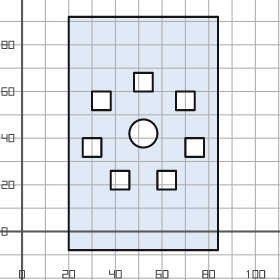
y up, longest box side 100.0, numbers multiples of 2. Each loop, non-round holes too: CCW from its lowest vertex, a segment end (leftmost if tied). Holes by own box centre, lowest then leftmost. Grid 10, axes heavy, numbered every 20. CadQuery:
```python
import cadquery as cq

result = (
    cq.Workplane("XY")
    .moveTo(20.0, -8.0)
    .lineTo(84.0, -8.0)
    .lineTo(84.0, 92.0)
    .lineTo(20.0, 92.0)
    .close()
    .moveTo(38.0, 18.0)
    .lineTo(46.0, 18.0)
    .lineTo(46.0, 26.0)
    .lineTo(38.0, 26.0)
    .close()
    .moveTo(58.0, 18.0)
    .lineTo(66.0, 18.0)
    .lineTo(66.0, 26.0)
    .lineTo(58.0, 26.0)
    .close()
    .moveTo(26.0, 32.0)
    .lineTo(34.0, 32.0)
    .lineTo(34.0, 40.0)
    .lineTo(26.0, 40.0)
    .close()
    .moveTo(70.0, 32.0)
    .lineTo(78.0, 32.0)
    .lineTo(78.0, 40.0)
    .lineTo(70.0, 40.0)
    .close()
    .moveTo(52.0, 42.0)
    .circle(6.0)
    .moveTo(30.0, 52.0)
    .lineTo(38.0, 52.0)
    .lineTo(38.0, 60.0)
    .lineTo(30.0, 60.0)
    .close()
    .moveTo(66.0, 52.0)
    .lineTo(74.0, 52.0)
    .lineTo(74.0, 60.0)
    .lineTo(66.0, 60.0)
    .close()
    .moveTo(48.0, 60.0)
    .lineTo(56.0, 60.0)
    .lineTo(56.0, 68.0)
    .lineTo(48.0, 68.0)
    .close()
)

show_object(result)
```